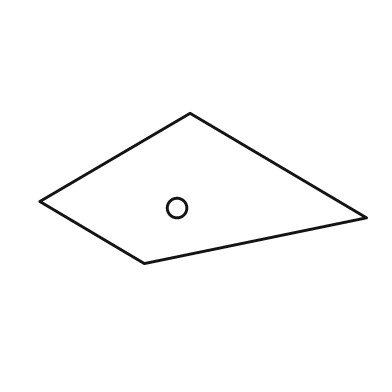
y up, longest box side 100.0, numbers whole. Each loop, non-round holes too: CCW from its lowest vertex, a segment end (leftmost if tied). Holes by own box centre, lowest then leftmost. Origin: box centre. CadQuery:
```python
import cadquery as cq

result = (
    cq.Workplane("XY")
    .moveTo(-18.0, -23.0)
    .lineTo(50.0, -9.0)
    .lineTo(-4.0, 23.0)
    .lineTo(-50.0, -4.0)
    .close()
    .moveTo(-8.0, -6.0)
    .circle(3.0)
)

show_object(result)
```